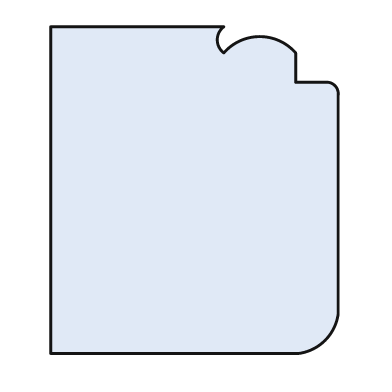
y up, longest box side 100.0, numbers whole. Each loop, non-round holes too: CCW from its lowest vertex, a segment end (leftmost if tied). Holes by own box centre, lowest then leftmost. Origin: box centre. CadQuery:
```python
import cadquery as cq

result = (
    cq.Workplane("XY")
    .moveTo(-44.0, -50.0)
    .lineTo(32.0, -50.0)
    .threePointArc((40.0, -46.0), (44.0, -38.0))
    .lineTo(44.0, 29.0)
    .threePointArc((43.0, 32.0), (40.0, 33.0))
    .lineTo(31.0, 33.0)
    .lineTo(31.0, 42.0)
    .threePointArc((20.0, 47.0), (9.0, 42.0))
    .threePointArc((7.0, 46.0), (9.0, 50.0))
    .lineTo(-44.0, 50.0)
    .close()
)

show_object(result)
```